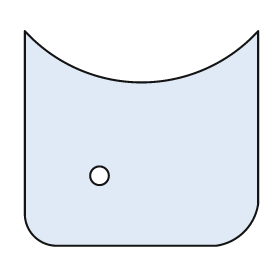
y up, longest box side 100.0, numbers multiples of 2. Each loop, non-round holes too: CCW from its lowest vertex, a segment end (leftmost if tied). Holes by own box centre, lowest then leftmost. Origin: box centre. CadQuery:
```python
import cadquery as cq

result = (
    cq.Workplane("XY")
    .moveTo(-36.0, -46.0)
    .lineTo(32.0, -46.0)
    .threePointArc((44.0, -40.0), (50.0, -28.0))
    .lineTo(50.0, 46.0)
    .threePointArc((0.0, 24.0), (-50.0, 46.0))
    .lineTo(-50.0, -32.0)
    .threePointArc((-46.0, -42.0), (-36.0, -46.0))
    .close()
    .moveTo(-18.0, -16.0)
    .circle(4.0)
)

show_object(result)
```